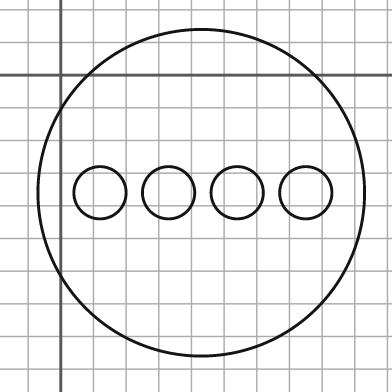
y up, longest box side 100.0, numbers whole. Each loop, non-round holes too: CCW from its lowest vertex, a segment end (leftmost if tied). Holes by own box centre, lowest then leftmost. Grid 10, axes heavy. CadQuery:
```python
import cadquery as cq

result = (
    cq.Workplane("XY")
    .moveTo(43.0, -36.0)
    .circle(50.0)
    .moveTo(12.0, -36.0)
    .circle(8.0)
    .moveTo(33.0, -36.0)
    .circle(8.0)
    .moveTo(54.0, -36.0)
    .circle(8.0)
    .moveTo(75.0, -36.0)
    .circle(8.0)
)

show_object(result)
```